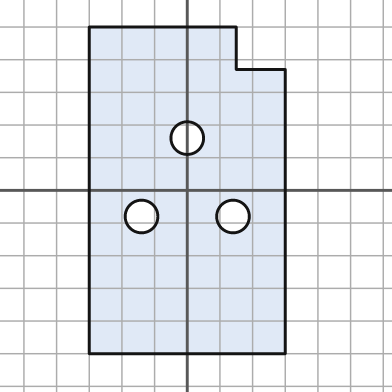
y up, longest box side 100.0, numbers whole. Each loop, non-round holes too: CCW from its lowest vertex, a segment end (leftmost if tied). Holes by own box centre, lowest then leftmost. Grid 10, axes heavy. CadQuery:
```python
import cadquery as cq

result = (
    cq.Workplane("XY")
    .moveTo(-30.0, -50.0)
    .lineTo(30.0, -50.0)
    .lineTo(30.0, 37.0)
    .lineTo(15.0, 37.0)
    .lineTo(15.0, 50.0)
    .lineTo(-30.0, 50.0)
    .close()
    .moveTo(-14.0, -8.0)
    .circle(5.0)
    .moveTo(14.0, -8.0)
    .circle(5.0)
    .moveTo(0.0, 16.0)
    .circle(5.0)
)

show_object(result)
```